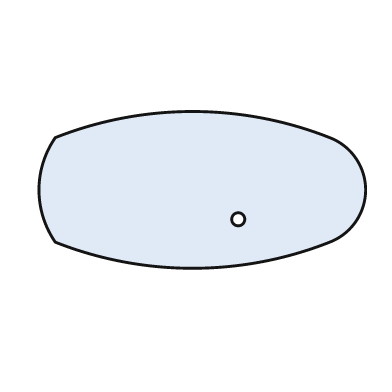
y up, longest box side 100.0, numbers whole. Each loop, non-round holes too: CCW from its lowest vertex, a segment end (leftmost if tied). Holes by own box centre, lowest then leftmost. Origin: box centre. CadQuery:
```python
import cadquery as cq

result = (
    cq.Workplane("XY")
    .moveTo(-45.0, -16.0)
    .threePointArc((-3.0, -24.0), (39.0, -16.0))
    .threePointArc((50.0, 0.0), (39.0, 16.0))
    .threePointArc((-3.0, 24.0), (-45.0, 16.0))
    .threePointArc((-50.0, 0.0), (-45.0, -16.0))
    .close()
    .moveTo(11.0, -9.0)
    .circle(2.0)
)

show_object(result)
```